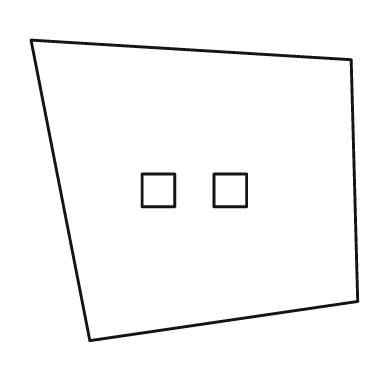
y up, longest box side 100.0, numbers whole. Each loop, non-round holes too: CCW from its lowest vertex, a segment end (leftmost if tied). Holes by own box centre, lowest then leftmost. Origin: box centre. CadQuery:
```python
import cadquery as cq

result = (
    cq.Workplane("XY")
    .moveTo(-32.0, -46.0)
    .lineTo(50.0, -34.0)
    .lineTo(48.0, 40.0)
    .lineTo(-50.0, 46.0)
    .close()
    .moveTo(-16.0, -5.0)
    .lineTo(-6.0, -5.0)
    .lineTo(-6.0, 5.0)
    .lineTo(-16.0, 5.0)
    .close()
    .moveTo(6.0, -5.0)
    .lineTo(16.0, -5.0)
    .lineTo(16.0, 5.0)
    .lineTo(6.0, 5.0)
    .close()
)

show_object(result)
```